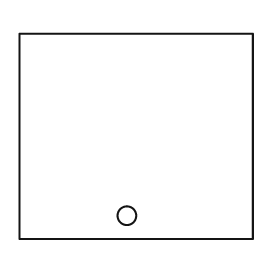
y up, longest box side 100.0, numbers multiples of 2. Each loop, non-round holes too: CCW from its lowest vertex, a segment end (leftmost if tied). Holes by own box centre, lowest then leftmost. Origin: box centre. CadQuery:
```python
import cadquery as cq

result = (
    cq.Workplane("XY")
    .moveTo(-50.0, -44.0)
    .lineTo(50.0, -44.0)
    .lineTo(50.0, 44.0)
    .lineTo(-50.0, 44.0)
    .close()
    .moveTo(-4.0, -34.0)
    .circle(4.0)
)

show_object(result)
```